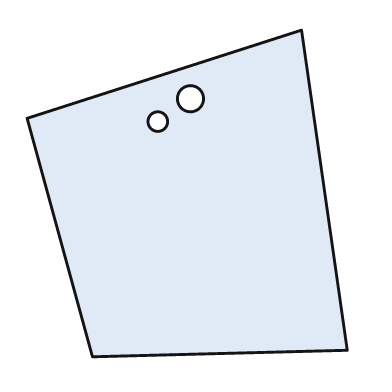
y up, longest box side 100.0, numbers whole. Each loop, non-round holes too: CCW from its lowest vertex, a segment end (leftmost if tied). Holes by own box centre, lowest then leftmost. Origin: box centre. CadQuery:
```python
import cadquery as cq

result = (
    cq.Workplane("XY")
    .moveTo(-29.0, -50.0)
    .lineTo(49.0, -48.0)
    .lineTo(35.0, 50.0)
    .lineTo(-49.0, 23.0)
    .close()
    .moveTo(-9.0, 22.0)
    .circle(3.0)
    .moveTo(1.0, 29.0)
    .circle(4.0)
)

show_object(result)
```